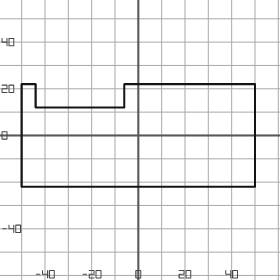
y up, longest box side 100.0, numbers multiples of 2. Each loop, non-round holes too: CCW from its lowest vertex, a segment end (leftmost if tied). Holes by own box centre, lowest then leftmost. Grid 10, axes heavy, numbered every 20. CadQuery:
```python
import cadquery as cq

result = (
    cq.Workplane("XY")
    .moveTo(-50.0, -22.0)
    .lineTo(50.0, -22.0)
    .lineTo(50.0, 22.0)
    .lineTo(-6.0, 22.0)
    .lineTo(-6.0, 12.0)
    .lineTo(-44.0, 12.0)
    .lineTo(-44.0, 22.0)
    .lineTo(-50.0, 22.0)
    .close()
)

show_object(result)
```